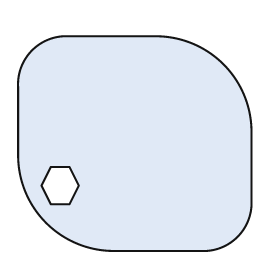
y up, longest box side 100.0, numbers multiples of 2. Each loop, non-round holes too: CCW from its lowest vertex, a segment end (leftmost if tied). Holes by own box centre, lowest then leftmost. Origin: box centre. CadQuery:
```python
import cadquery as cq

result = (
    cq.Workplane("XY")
    .moveTo(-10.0, -46.0)
    .lineTo(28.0, -46.0)
    .threePointArc((44.0, -40.0), (50.0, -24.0))
    .lineTo(50.0, 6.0)
    .threePointArc((38.0, 34.0), (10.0, 46.0))
    .lineTo(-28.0, 46.0)
    .threePointArc((-44.0, 40.0), (-50.0, 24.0))
    .lineTo(-50.0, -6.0)
    .threePointArc((-38.0, -34.0), (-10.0, -46.0))
    .close()
    .moveTo(-36.0, -26.0)
    .lineTo(-28.0, -26.0)
    .lineTo(-24.0, -18.0)
    .lineTo(-28.0, -10.0)
    .lineTo(-36.0, -10.0)
    .lineTo(-40.0, -18.0)
    .close()
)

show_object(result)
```